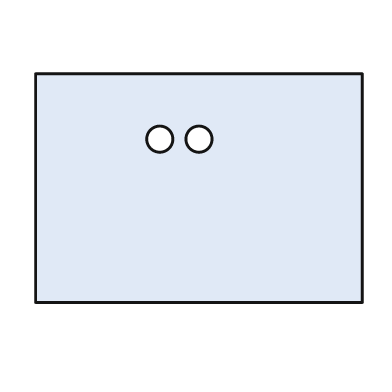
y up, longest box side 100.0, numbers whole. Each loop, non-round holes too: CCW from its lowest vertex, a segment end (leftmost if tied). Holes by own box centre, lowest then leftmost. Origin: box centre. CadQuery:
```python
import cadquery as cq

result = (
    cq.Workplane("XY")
    .moveTo(-50.0, -35.0)
    .lineTo(50.0, -35.0)
    .lineTo(50.0, 35.0)
    .lineTo(-50.0, 35.0)
    .close()
    .moveTo(-12.0, 15.0)
    .circle(4.0)
    .moveTo(0.0, 15.0)
    .circle(4.0)
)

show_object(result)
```